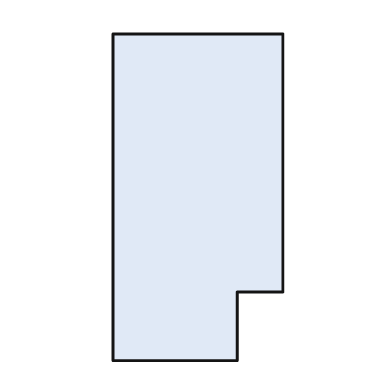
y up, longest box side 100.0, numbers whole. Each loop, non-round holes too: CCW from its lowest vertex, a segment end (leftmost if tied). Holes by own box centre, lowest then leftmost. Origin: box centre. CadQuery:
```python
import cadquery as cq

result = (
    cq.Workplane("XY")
    .moveTo(-26.0, -50.0)
    .lineTo(12.0, -50.0)
    .lineTo(12.0, -29.0)
    .lineTo(26.0, -29.0)
    .lineTo(26.0, 50.0)
    .lineTo(-26.0, 50.0)
    .close()
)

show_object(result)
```